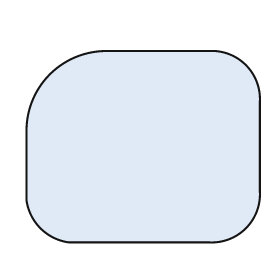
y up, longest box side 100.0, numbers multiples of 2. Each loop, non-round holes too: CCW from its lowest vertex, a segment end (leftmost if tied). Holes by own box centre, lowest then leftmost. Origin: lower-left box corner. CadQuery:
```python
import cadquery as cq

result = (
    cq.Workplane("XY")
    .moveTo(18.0, 0.0)
    .lineTo(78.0, 0.0)
    .threePointArc((94.0, 6.0), (100.0, 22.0))
    .lineTo(100.0, 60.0)
    .threePointArc((94.0, 76.0), (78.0, 82.0))
    .lineTo(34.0, 82.0)
    .threePointArc((10.0, 72.0), (0.0, 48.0))
    .lineTo(0.0, 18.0)
    .threePointArc((6.0, 6.0), (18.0, 0.0))
    .close()
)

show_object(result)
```